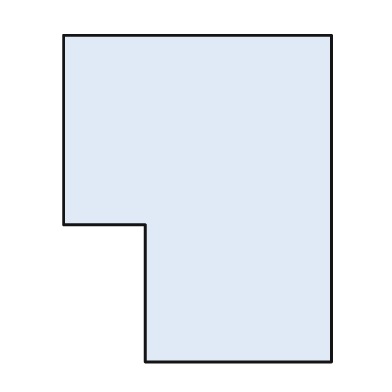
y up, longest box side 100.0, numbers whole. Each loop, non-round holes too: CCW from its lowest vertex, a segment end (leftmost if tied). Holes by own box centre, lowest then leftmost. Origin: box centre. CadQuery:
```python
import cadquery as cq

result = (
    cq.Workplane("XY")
    .moveTo(-16.0, -50.0)
    .lineTo(41.0, -50.0)
    .lineTo(41.0, 50.0)
    .lineTo(-41.0, 50.0)
    .lineTo(-41.0, -8.0)
    .lineTo(-16.0, -8.0)
    .close()
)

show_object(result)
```